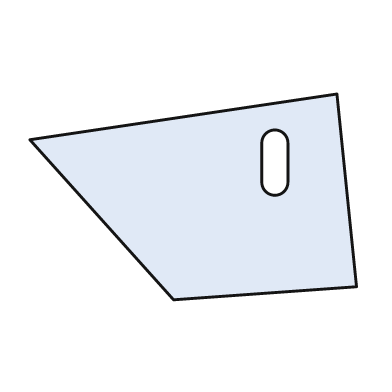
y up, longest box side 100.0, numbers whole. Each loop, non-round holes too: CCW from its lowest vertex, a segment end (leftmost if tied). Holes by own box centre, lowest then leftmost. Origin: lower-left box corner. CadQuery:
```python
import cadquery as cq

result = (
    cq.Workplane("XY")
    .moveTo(44.0, 0.0)
    .lineTo(100.0, 4.0)
    .lineTo(94.0, 63.0)
    .lineTo(0.0, 49.0)
    .close()
    .moveTo(71.0, 36.0)
    .threePointArc((75.0, 32.0), (79.0, 36.0))
    .lineTo(79.0, 48.0)
    .threePointArc((75.0, 52.0), (71.0, 48.0))
    .close()
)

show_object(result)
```